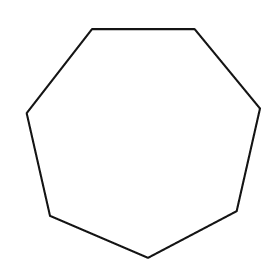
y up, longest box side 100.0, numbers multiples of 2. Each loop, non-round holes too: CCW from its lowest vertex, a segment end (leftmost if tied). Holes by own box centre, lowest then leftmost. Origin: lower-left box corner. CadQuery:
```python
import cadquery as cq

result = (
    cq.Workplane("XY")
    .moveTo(52.0, 0.0)
    .lineTo(90.0, 20.0)
    .lineTo(100.0, 64.0)
    .lineTo(72.0, 98.0)
    .lineTo(28.0, 98.0)
    .lineTo(0.0, 62.0)
    .lineTo(10.0, 18.0)
    .close()
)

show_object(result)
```